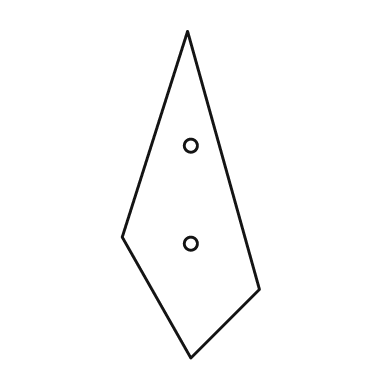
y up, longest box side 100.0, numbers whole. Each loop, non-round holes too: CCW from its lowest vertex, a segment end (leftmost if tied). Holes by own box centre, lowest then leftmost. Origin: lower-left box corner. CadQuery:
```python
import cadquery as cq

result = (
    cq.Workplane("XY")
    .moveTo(21.0, 0.0)
    .lineTo(42.0, 21.0)
    .lineTo(20.0, 100.0)
    .lineTo(0.0, 37.0)
    .close()
    .moveTo(21.0, 35.0)
    .circle(2.0)
    .moveTo(21.0, 65.0)
    .circle(2.0)
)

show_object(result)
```